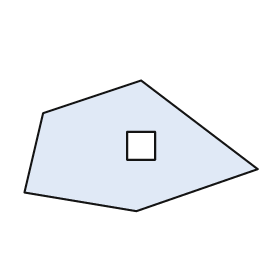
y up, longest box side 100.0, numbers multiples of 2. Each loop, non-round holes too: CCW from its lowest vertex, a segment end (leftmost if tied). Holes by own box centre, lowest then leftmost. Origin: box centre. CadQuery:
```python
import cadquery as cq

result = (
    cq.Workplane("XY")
    .moveTo(-2.0, -28.0)
    .lineTo(50.0, -10.0)
    .lineTo(0.0, 28.0)
    .lineTo(-42.0, 14.0)
    .lineTo(-50.0, -20.0)
    .close()
    .moveTo(-6.0, -6.0)
    .lineTo(6.0, -6.0)
    .lineTo(6.0, 6.0)
    .lineTo(-6.0, 6.0)
    .close()
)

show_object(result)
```